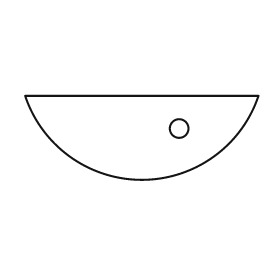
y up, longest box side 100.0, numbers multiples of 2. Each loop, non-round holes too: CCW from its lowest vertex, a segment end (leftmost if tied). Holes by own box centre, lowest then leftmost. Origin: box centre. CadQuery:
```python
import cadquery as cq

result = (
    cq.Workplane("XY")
    .moveTo(-50.0, 18.0)
    .threePointArc((0.0, -18.0), (50.0, 18.0))
    .close()
    .moveTo(16.0, 4.0)
    .circle(4.0)
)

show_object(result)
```